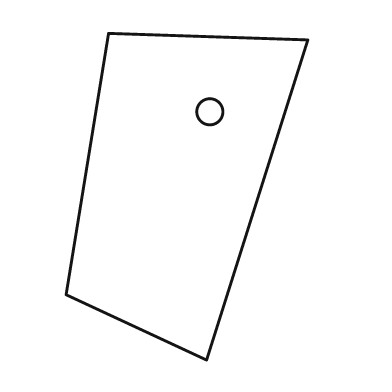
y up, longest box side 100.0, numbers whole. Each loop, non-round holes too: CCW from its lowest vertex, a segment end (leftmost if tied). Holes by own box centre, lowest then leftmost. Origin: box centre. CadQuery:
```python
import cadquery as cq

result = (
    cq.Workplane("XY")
    .moveTo(6.0, -50.0)
    .lineTo(37.0, 48.0)
    .lineTo(-24.0, 50.0)
    .lineTo(-37.0, -30.0)
    .close()
    .moveTo(7.0, 26.0)
    .circle(4.0)
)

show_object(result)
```